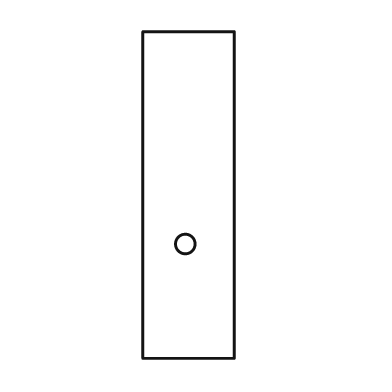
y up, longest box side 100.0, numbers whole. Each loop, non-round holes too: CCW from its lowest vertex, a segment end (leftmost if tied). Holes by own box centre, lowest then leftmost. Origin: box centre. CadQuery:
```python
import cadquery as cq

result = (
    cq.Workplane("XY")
    .moveTo(-14.0, -50.0)
    .lineTo(14.0, -50.0)
    .lineTo(14.0, 50.0)
    .lineTo(-14.0, 50.0)
    .close()
    .moveTo(-1.0, -15.0)
    .circle(3.0)
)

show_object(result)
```